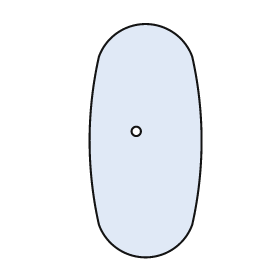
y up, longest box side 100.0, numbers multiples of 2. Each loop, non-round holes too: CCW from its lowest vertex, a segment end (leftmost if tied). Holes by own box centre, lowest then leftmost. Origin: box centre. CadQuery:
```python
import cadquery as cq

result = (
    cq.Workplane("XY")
    .moveTo(-20.0, -36.0)
    .threePointArc((0.0, -50.0), (20.0, -36.0))
    .threePointArc((24.0, 0.0), (20.0, 36.0))
    .threePointArc((0.0, 50.0), (-20.0, 36.0))
    .threePointArc((-24.0, 0.0), (-20.0, -36.0))
    .close()
    .moveTo(-4.0, 4.0)
    .circle(2.0)
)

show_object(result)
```